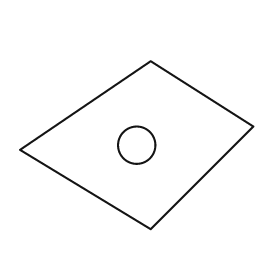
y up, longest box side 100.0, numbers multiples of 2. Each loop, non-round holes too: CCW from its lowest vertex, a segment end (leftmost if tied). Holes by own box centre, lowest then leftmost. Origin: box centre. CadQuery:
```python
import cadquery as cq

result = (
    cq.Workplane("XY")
    .moveTo(6.0, -36.0)
    .lineTo(50.0, 8.0)
    .lineTo(6.0, 36.0)
    .lineTo(-50.0, -2.0)
    .close()
    .moveTo(0.0, 0.0)
    .circle(8.0)
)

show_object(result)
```